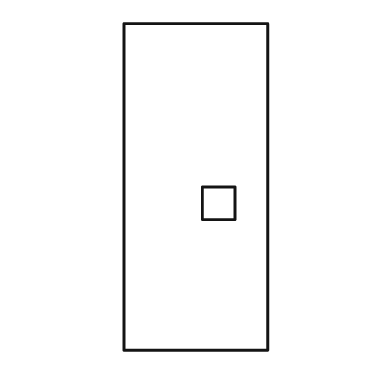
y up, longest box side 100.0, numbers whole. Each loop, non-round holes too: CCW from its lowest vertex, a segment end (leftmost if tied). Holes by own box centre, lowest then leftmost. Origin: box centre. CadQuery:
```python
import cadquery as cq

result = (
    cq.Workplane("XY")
    .moveTo(-22.0, -50.0)
    .lineTo(22.0, -50.0)
    .lineTo(22.0, 50.0)
    .lineTo(-22.0, 50.0)
    .close()
    .moveTo(2.0, -10.0)
    .lineTo(12.0, -10.0)
    .lineTo(12.0, 0.0)
    .lineTo(2.0, 0.0)
    .close()
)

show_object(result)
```